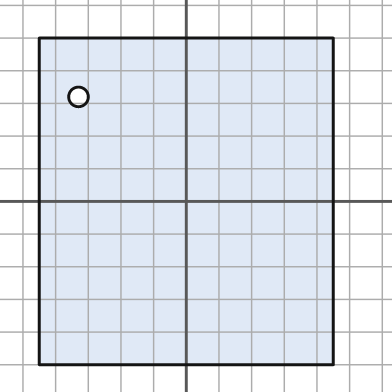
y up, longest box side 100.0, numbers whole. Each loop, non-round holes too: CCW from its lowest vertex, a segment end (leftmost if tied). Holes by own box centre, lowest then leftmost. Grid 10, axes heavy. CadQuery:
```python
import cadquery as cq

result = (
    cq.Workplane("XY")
    .moveTo(-45.0, -50.0)
    .lineTo(45.0, -50.0)
    .lineTo(45.0, 50.0)
    .lineTo(-45.0, 50.0)
    .close()
    .moveTo(-33.0, 32.0)
    .circle(3.0)
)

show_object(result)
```